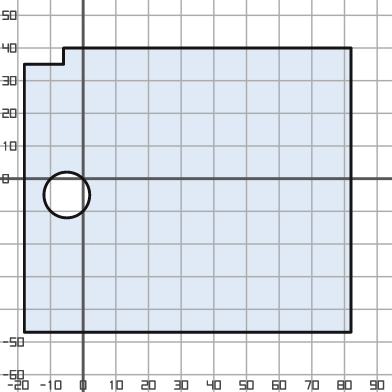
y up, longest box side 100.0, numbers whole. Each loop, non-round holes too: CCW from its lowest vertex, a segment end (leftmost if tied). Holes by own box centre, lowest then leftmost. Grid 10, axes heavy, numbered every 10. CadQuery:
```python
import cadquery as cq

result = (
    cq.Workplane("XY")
    .moveTo(-18.0, -47.0)
    .lineTo(82.0, -47.0)
    .lineTo(82.0, 40.0)
    .lineTo(-6.0, 40.0)
    .lineTo(-6.0, 35.0)
    .lineTo(-18.0, 35.0)
    .close()
    .moveTo(-5.0, -5.0)
    .circle(7.0)
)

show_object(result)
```